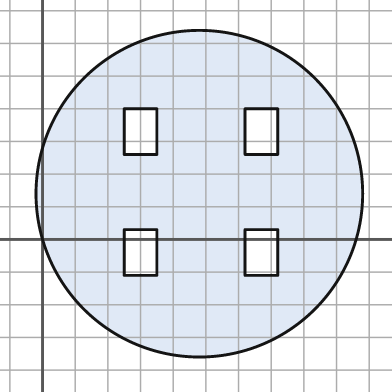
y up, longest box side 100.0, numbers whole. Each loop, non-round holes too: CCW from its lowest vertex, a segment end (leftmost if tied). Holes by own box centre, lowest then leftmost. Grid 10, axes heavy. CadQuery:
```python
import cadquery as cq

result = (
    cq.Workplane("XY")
    .moveTo(48.0, 14.0)
    .circle(50.0)
    .moveTo(25.0, -11.0)
    .lineTo(35.0, -11.0)
    .lineTo(35.0, 3.0)
    .lineTo(25.0, 3.0)
    .close()
    .moveTo(62.0, -11.0)
    .lineTo(72.0, -11.0)
    .lineTo(72.0, 3.0)
    .lineTo(62.0, 3.0)
    .close()
    .moveTo(25.0, 26.0)
    .lineTo(35.0, 26.0)
    .lineTo(35.0, 40.0)
    .lineTo(25.0, 40.0)
    .close()
    .moveTo(62.0, 26.0)
    .lineTo(72.0, 26.0)
    .lineTo(72.0, 40.0)
    .lineTo(62.0, 40.0)
    .close()
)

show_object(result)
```